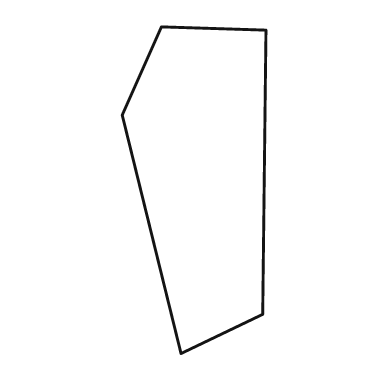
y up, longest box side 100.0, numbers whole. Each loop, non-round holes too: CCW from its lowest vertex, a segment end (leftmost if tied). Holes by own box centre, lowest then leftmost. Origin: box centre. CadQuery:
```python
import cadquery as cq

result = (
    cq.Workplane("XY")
    .moveTo(-4.0, -50.0)
    .lineTo(21.0, -38.0)
    .lineTo(22.0, 49.0)
    .lineTo(-10.0, 50.0)
    .lineTo(-22.0, 23.0)
    .close()
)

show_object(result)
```